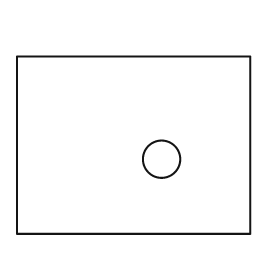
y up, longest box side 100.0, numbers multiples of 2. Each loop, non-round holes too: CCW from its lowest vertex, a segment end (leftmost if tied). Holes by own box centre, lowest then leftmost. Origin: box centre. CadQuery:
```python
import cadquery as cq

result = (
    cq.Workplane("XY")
    .moveTo(-50.0, -38.0)
    .lineTo(50.0, -38.0)
    .lineTo(50.0, 38.0)
    .lineTo(-50.0, 38.0)
    .close()
    .moveTo(12.0, -6.0)
    .circle(8.0)
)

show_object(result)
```